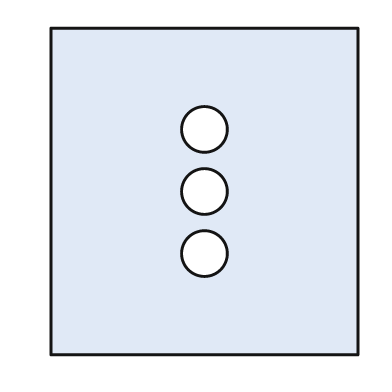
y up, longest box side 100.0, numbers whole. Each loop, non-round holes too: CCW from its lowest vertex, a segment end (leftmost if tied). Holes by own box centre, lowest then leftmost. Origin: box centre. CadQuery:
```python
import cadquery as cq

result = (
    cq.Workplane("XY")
    .moveTo(-47.0, -50.0)
    .lineTo(47.0, -50.0)
    .lineTo(47.0, 50.0)
    .lineTo(-47.0, 50.0)
    .close()
    .moveTo(0.0, -19.0)
    .circle(7.0)
    .moveTo(0.0, 0.0)
    .circle(7.0)
    .moveTo(0.0, 19.0)
    .circle(7.0)
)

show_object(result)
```